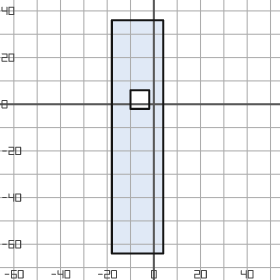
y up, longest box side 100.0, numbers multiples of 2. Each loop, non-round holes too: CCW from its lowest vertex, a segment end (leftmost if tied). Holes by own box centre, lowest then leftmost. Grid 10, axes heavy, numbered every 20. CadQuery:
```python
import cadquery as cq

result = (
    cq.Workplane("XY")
    .moveTo(-18.0, -64.0)
    .lineTo(4.0, -64.0)
    .lineTo(4.0, 36.0)
    .lineTo(-18.0, 36.0)
    .close()
    .moveTo(-10.0, -2.0)
    .lineTo(-2.0, -2.0)
    .lineTo(-2.0, 6.0)
    .lineTo(-10.0, 6.0)
    .close()
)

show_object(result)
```